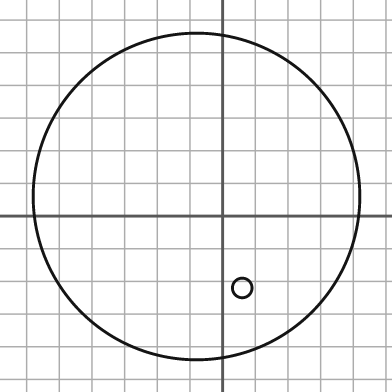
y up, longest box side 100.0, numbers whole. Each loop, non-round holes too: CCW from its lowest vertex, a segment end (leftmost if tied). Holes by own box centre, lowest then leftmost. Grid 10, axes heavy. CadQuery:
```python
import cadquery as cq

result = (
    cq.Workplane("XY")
    .moveTo(-8.0, 6.0)
    .circle(50.0)
    .moveTo(6.0, -22.0)
    .circle(3.0)
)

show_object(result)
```